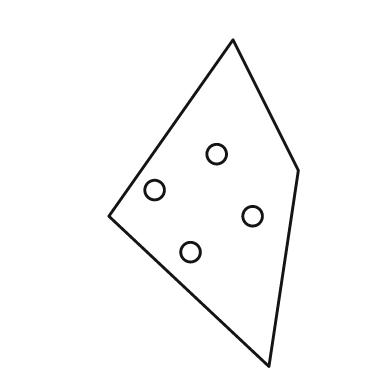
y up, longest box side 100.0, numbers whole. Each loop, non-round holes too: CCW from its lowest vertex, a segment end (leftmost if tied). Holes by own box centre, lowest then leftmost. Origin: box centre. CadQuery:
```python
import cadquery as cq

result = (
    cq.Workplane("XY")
    .moveTo(20.0, -50.0)
    .lineTo(29.0, 10.0)
    .lineTo(9.0, 50.0)
    .lineTo(-29.0, -4.0)
    .close()
    .moveTo(-4.0, -15.0)
    .circle(3.0)
    .moveTo(15.0, -4.0)
    .circle(3.0)
    .moveTo(-15.0, 4.0)
    .circle(3.0)
    .moveTo(4.0, 15.0)
    .circle(3.0)
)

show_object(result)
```